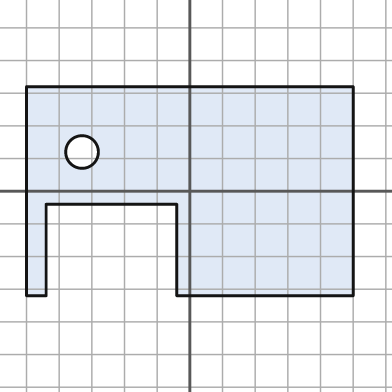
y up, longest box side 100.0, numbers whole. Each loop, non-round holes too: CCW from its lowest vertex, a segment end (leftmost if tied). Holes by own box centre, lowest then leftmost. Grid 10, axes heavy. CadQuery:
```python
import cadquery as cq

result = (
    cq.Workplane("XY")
    .moveTo(-50.0, -32.0)
    .lineTo(-44.0, -32.0)
    .lineTo(-44.0, -4.0)
    .lineTo(-4.0, -4.0)
    .lineTo(-4.0, -32.0)
    .lineTo(50.0, -32.0)
    .lineTo(50.0, 32.0)
    .lineTo(-50.0, 32.0)
    .close()
    .moveTo(-33.0, 12.0)
    .circle(5.0)
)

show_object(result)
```